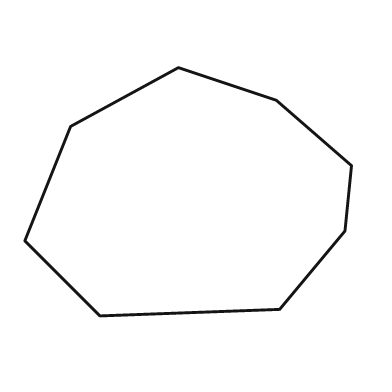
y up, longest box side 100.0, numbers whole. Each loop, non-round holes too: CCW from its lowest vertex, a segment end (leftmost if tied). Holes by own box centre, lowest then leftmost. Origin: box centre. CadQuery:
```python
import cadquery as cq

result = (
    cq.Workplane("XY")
    .moveTo(-27.0, -38.0)
    .lineTo(28.0, -36.0)
    .lineTo(48.0, -12.0)
    .lineTo(50.0, 8.0)
    .lineTo(27.0, 28.0)
    .lineTo(-3.0, 38.0)
    .lineTo(-36.0, 20.0)
    .lineTo(-50.0, -15.0)
    .close()
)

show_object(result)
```